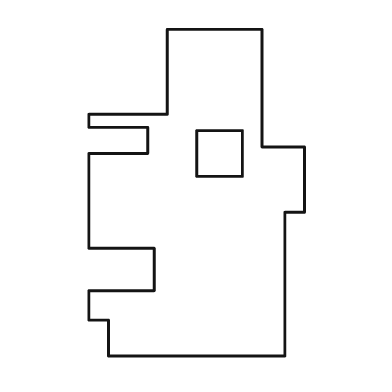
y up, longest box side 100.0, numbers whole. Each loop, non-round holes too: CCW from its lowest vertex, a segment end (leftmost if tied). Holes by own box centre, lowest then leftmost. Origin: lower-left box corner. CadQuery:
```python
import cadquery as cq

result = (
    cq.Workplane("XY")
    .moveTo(6.0, 0.0)
    .lineTo(60.0, 0.0)
    .lineTo(60.0, 44.0)
    .lineTo(66.0, 44.0)
    .lineTo(66.0, 64.0)
    .lineTo(53.0, 64.0)
    .lineTo(53.0, 100.0)
    .lineTo(24.0, 100.0)
    .lineTo(24.0, 74.0)
    .lineTo(0.0, 74.0)
    .lineTo(0.0, 70.0)
    .lineTo(18.0, 70.0)
    .lineTo(18.0, 62.0)
    .lineTo(0.0, 62.0)
    .lineTo(0.0, 33.0)
    .lineTo(20.0, 33.0)
    .lineTo(20.0, 20.0)
    .lineTo(0.0, 20.0)
    .lineTo(0.0, 11.0)
    .lineTo(6.0, 11.0)
    .close()
    .moveTo(33.0, 55.0)
    .lineTo(47.0, 55.0)
    .lineTo(47.0, 69.0)
    .lineTo(33.0, 69.0)
    .close()
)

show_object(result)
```